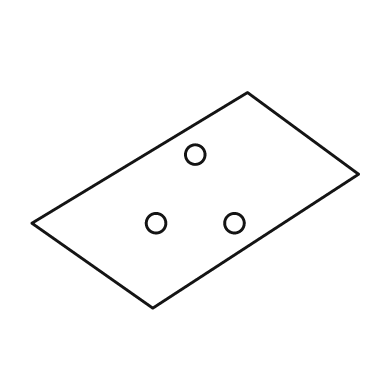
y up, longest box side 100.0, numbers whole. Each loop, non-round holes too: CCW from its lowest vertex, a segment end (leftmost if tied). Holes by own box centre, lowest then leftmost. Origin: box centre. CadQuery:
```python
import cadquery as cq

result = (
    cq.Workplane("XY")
    .moveTo(-13.0, -33.0)
    .lineTo(50.0, 8.0)
    .lineTo(16.0, 33.0)
    .lineTo(-50.0, -7.0)
    .close()
    .moveTo(-12.0, -7.0)
    .circle(3.0)
    .moveTo(12.0, -7.0)
    .circle(3.0)
    .moveTo(0.0, 14.0)
    .circle(3.0)
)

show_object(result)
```